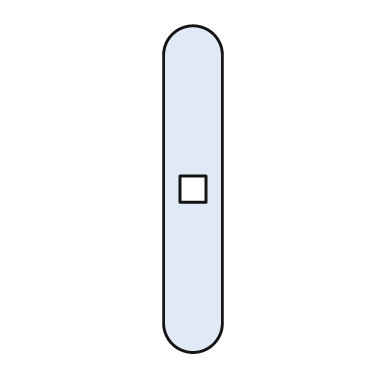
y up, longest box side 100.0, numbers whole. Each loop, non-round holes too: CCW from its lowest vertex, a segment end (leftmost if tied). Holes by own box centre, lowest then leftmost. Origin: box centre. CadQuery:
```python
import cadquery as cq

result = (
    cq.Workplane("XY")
    .moveTo(-9.0, -41.0)
    .threePointArc((0.0, -50.0), (9.0, -41.0))
    .lineTo(9.0, 41.0)
    .threePointArc((0.0, 50.0), (-9.0, 41.0))
    .close()
    .moveTo(-4.0, -4.0)
    .lineTo(4.0, -4.0)
    .lineTo(4.0, 4.0)
    .lineTo(-4.0, 4.0)
    .close()
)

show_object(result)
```